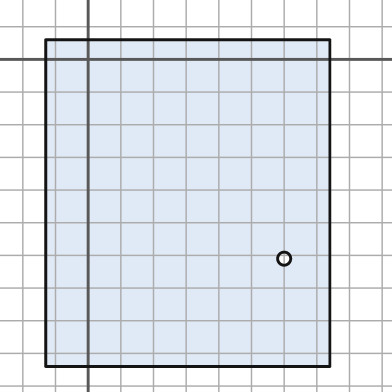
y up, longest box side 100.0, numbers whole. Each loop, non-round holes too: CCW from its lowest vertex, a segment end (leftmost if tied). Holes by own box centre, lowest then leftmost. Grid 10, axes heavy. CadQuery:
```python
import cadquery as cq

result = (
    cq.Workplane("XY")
    .moveTo(-13.0, -94.0)
    .lineTo(74.0, -94.0)
    .lineTo(74.0, 6.0)
    .lineTo(-13.0, 6.0)
    .close()
    .moveTo(60.0, -61.0)
    .circle(2.0)
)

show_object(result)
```